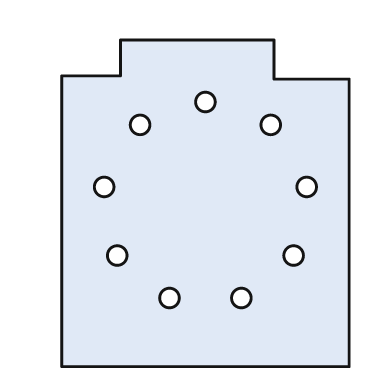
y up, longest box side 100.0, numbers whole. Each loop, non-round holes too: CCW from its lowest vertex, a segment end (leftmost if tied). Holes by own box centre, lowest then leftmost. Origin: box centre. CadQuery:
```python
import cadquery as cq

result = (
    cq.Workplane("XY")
    .moveTo(-44.0, -50.0)
    .lineTo(44.0, -50.0)
    .lineTo(44.0, 38.0)
    .lineTo(21.0, 38.0)
    .lineTo(21.0, 50.0)
    .lineTo(-26.0, 50.0)
    .lineTo(-26.0, 39.0)
    .lineTo(-44.0, 39.0)
    .close()
    .moveTo(-11.0, -29.0)
    .circle(3.0)
    .moveTo(11.0, -29.0)
    .circle(3.0)
    .moveTo(-27.0, -16.0)
    .circle(3.0)
    .moveTo(27.0, -16.0)
    .circle(3.0)
    .moveTo(-31.0, 5.0)
    .circle(3.0)
    .moveTo(31.0, 5.0)
    .circle(3.0)
    .moveTo(-20.0, 24.0)
    .circle(3.0)
    .moveTo(20.0, 24.0)
    .circle(3.0)
    .moveTo(0.0, 31.0)
    .circle(3.0)
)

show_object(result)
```